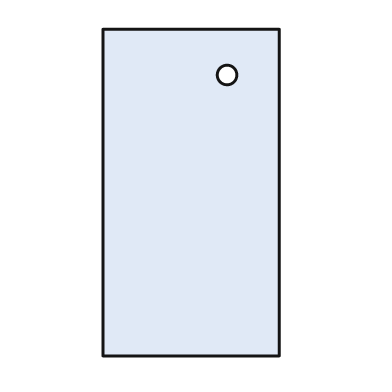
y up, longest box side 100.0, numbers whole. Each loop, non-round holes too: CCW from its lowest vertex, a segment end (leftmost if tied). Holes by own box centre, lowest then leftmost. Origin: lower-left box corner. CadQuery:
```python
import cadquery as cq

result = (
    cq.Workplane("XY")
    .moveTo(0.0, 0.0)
    .lineTo(54.0, 0.0)
    .lineTo(54.0, 100.0)
    .lineTo(0.0, 100.0)
    .close()
    .moveTo(38.0, 86.0)
    .circle(3.0)
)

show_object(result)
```